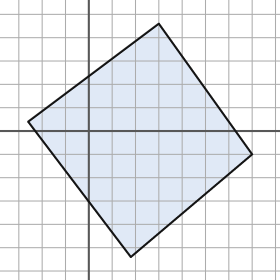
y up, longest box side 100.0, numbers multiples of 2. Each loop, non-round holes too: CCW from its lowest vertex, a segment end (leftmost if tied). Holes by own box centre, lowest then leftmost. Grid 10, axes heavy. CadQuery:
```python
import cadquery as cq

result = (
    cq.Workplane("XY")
    .moveTo(18.0, -54.0)
    .lineTo(70.0, -10.0)
    .lineTo(30.0, 46.0)
    .lineTo(-26.0, 4.0)
    .close()
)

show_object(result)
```